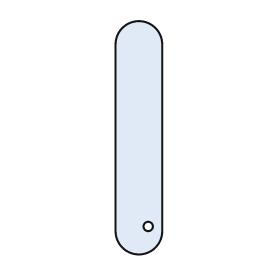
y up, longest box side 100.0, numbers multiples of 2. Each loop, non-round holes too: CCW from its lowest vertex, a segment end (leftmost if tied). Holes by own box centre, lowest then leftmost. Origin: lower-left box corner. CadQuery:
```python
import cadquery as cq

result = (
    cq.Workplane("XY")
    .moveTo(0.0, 10.0)
    .threePointArc((10.0, 0.0), (20.0, 10.0))
    .lineTo(20.0, 90.0)
    .threePointArc((10.0, 100.0), (0.0, 90.0))
    .close()
    .moveTo(14.0, 12.0)
    .circle(2.0)
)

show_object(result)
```